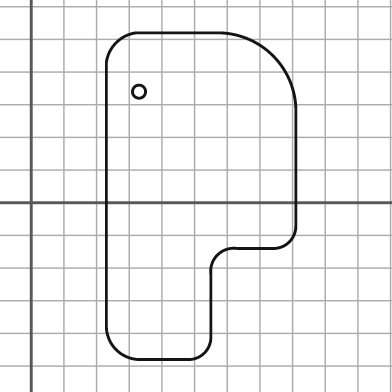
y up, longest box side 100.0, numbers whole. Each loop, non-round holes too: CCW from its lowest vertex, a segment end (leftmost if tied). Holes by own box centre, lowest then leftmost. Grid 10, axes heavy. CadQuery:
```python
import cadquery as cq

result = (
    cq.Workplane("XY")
    .moveTo(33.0, -48.0)
    .lineTo(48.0, -48.0)
    .threePointArc((53.0, -46.0), (55.0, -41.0))
    .lineTo(55.0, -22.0)
    .threePointArc((57.0, -16.0), (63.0, -14.0))
    .lineTo(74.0, -14.0)
    .threePointArc((79.0, -12.0), (81.0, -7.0))
    .lineTo(81.0, 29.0)
    .threePointArc((74.0, 45.0), (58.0, 52.0))
    .lineTo(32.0, 52.0)
    .threePointArc((26.0, 49.0), (23.0, 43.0))
    .lineTo(23.0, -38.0)
    .threePointArc((26.0, -45.0), (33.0, -48.0))
    .close()
    .moveTo(33.0, 34.0)
    .circle(2.0)
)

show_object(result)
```